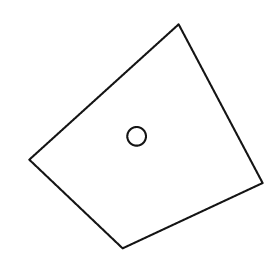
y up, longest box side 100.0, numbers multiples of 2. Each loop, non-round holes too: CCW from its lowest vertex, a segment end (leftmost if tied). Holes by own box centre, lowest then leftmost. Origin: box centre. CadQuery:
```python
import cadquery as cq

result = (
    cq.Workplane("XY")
    .moveTo(-10.0, -48.0)
    .lineTo(50.0, -20.0)
    .lineTo(14.0, 48.0)
    .lineTo(-50.0, -10.0)
    .close()
    .moveTo(-4.0, 0.0)
    .circle(4.0)
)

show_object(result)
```